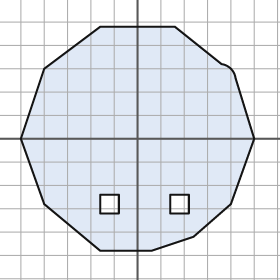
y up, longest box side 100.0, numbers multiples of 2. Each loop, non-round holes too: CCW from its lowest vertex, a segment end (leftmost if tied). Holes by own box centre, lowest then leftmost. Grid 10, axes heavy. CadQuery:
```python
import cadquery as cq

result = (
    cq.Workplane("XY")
    .moveTo(-16.0, -48.0)
    .lineTo(6.0, -48.0)
    .lineTo(24.0, -42.0)
    .lineTo(40.0, -28.0)
    .lineTo(50.0, 0.0)
    .lineTo(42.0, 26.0)
    .threePointArc((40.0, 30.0), (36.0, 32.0))
    .lineTo(16.0, 48.0)
    .lineTo(-16.0, 48.0)
    .lineTo(-40.0, 30.0)
    .lineTo(-50.0, 0.0)
    .lineTo(-40.0, -28.0)
    .close()
    .moveTo(-16.0, -32.0)
    .lineTo(-8.0, -32.0)
    .lineTo(-8.0, -24.0)
    .lineTo(-16.0, -24.0)
    .close()
    .moveTo(14.0, -32.0)
    .lineTo(22.0, -32.0)
    .lineTo(22.0, -24.0)
    .lineTo(14.0, -24.0)
    .close()
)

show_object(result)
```